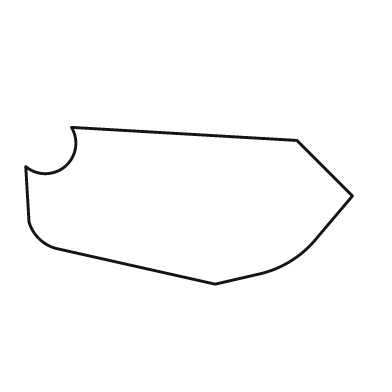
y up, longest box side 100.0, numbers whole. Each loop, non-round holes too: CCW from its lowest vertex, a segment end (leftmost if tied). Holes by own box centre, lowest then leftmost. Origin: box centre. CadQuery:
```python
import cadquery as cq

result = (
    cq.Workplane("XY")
    .moveTo(8.0, -24.0)
    .lineTo(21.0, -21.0)
    .threePointArc((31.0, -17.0), (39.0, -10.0))
    .lineTo(50.0, 3.0)
    .lineTo(33.0, 20.0)
    .lineTo(-36.0, 24.0)
    .threePointArc((-38.0, 12.0), (-50.0, 12.0))
    .lineTo(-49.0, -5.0)
    .threePointArc((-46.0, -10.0), (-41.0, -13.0))
    .close()
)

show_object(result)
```